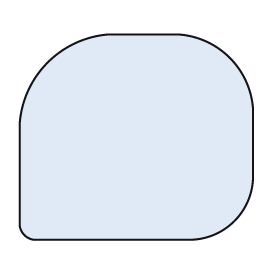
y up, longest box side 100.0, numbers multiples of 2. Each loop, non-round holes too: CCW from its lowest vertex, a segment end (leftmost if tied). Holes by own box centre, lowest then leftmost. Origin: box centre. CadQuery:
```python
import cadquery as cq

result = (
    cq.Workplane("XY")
    .moveTo(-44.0, -44.0)
    .lineTo(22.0, -44.0)
    .threePointArc((42.0, -36.0), (50.0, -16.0))
    .lineTo(50.0, 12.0)
    .threePointArc((40.0, 34.0), (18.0, 44.0))
    .lineTo(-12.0, 44.0)
    .threePointArc((-38.0, 32.0), (-50.0, 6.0))
    .lineTo(-50.0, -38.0)
    .threePointArc((-48.0, -42.0), (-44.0, -44.0))
    .close()
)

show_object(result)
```